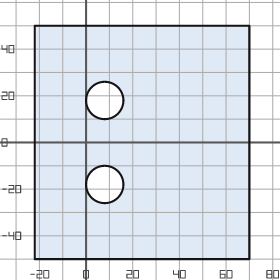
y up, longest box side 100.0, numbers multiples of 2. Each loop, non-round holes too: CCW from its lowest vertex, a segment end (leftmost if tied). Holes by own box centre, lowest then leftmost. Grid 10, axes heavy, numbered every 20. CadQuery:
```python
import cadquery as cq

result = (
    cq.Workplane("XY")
    .moveTo(-22.0, -50.0)
    .lineTo(70.0, -50.0)
    .lineTo(70.0, 50.0)
    .lineTo(-22.0, 50.0)
    .close()
    .moveTo(8.0, -18.0)
    .circle(8.0)
    .moveTo(8.0, 18.0)
    .circle(8.0)
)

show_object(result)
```